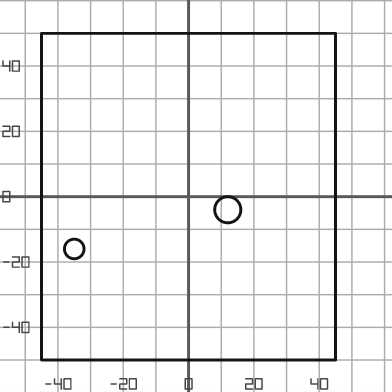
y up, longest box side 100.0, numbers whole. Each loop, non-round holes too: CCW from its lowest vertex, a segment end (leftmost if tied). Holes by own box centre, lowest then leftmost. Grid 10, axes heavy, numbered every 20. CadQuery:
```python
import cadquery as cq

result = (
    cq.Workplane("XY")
    .moveTo(-45.0, -50.0)
    .lineTo(45.0, -50.0)
    .lineTo(45.0, 50.0)
    .lineTo(-45.0, 50.0)
    .close()
    .moveTo(-35.0, -16.0)
    .circle(3.0)
    .moveTo(12.0, -4.0)
    .circle(4.0)
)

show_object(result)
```